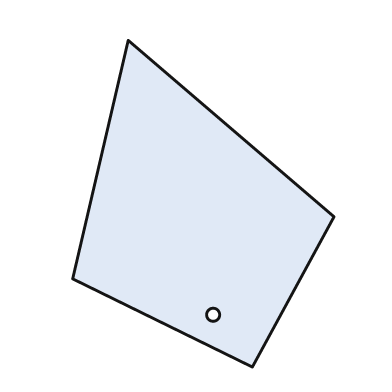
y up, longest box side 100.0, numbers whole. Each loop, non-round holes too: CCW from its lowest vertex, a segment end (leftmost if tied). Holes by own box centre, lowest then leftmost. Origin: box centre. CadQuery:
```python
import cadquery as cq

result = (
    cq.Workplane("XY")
    .moveTo(15.0, -50.0)
    .lineTo(40.0, -4.0)
    .lineTo(-23.0, 50.0)
    .lineTo(-40.0, -23.0)
    .close()
    .moveTo(3.0, -34.0)
    .circle(2.0)
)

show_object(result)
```